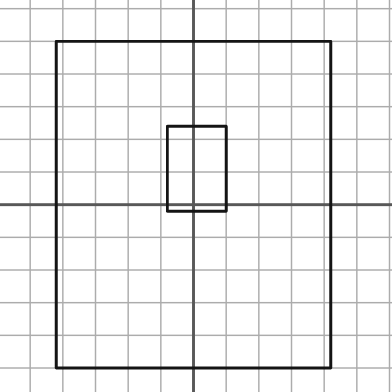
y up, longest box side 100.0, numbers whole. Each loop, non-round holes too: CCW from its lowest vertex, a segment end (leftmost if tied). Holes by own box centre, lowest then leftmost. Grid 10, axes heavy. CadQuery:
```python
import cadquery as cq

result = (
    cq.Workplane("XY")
    .moveTo(-42.0, -50.0)
    .lineTo(42.0, -50.0)
    .lineTo(42.0, 50.0)
    .lineTo(-42.0, 50.0)
    .close()
    .moveTo(-8.0, -2.0)
    .lineTo(10.0, -2.0)
    .lineTo(10.0, 24.0)
    .lineTo(-8.0, 24.0)
    .close()
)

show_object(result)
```